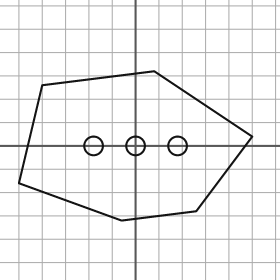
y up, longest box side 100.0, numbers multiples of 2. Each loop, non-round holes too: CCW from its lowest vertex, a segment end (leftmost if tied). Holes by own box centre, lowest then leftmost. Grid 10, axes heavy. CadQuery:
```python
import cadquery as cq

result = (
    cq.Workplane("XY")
    .moveTo(-6.0, -32.0)
    .lineTo(26.0, -28.0)
    .lineTo(50.0, 4.0)
    .lineTo(8.0, 32.0)
    .lineTo(-40.0, 26.0)
    .lineTo(-50.0, -16.0)
    .close()
    .moveTo(-18.0, 0.0)
    .circle(4.0)
    .moveTo(0.0, 0.0)
    .circle(4.0)
    .moveTo(18.0, 0.0)
    .circle(4.0)
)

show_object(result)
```